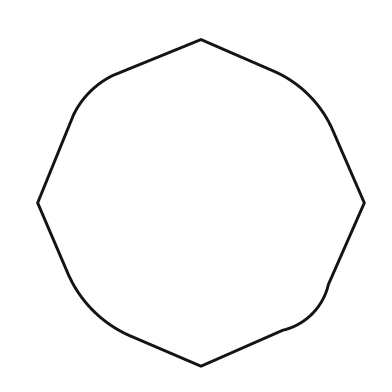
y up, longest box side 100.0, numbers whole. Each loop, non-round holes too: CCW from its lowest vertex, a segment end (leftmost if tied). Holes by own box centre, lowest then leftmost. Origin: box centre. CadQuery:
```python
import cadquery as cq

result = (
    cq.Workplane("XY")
    .moveTo(0.0, -50.0)
    .lineTo(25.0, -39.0)
    .threePointArc((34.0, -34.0), (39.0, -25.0))
    .lineTo(50.0, 0.0)
    .lineTo(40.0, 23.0)
    .threePointArc((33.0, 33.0), (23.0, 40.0))
    .lineTo(0.0, 50.0)
    .lineTo(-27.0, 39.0)
    .threePointArc((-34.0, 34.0), (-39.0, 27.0))
    .lineTo(-50.0, 0.0)
    .lineTo(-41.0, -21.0)
    .threePointArc((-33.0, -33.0), (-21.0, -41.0))
    .close()
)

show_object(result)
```